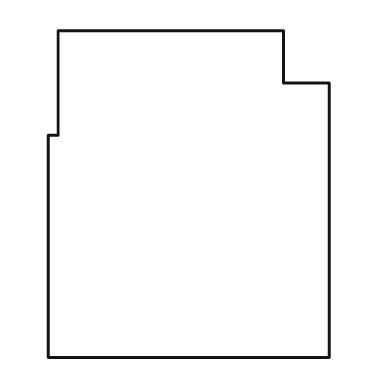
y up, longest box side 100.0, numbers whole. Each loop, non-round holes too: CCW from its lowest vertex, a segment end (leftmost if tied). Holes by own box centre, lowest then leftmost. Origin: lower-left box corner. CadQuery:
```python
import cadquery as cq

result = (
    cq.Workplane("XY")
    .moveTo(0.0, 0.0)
    .lineTo(86.0, 0.0)
    .lineTo(86.0, 84.0)
    .lineTo(72.0, 84.0)
    .lineTo(72.0, 100.0)
    .lineTo(3.0, 100.0)
    .lineTo(3.0, 68.0)
    .lineTo(0.0, 68.0)
    .close()
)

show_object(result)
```